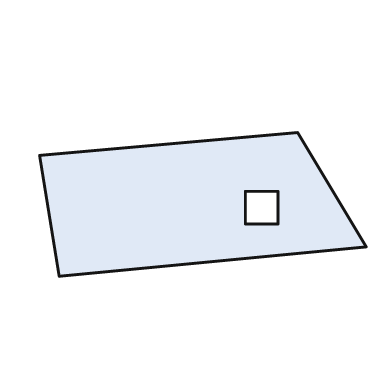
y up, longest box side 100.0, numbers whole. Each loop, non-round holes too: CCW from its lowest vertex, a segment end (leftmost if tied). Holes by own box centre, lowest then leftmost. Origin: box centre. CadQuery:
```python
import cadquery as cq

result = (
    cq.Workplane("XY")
    .moveTo(-44.0, -22.0)
    .lineTo(50.0, -13.0)
    .lineTo(29.0, 22.0)
    .lineTo(-50.0, 15.0)
    .close()
    .moveTo(13.0, -6.0)
    .lineTo(23.0, -6.0)
    .lineTo(23.0, 4.0)
    .lineTo(13.0, 4.0)
    .close()
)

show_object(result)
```